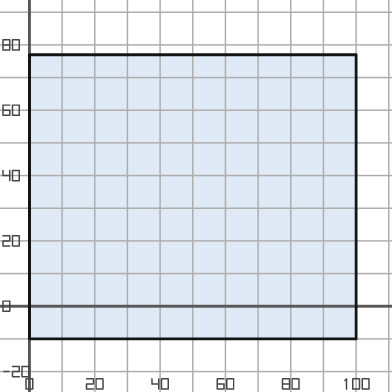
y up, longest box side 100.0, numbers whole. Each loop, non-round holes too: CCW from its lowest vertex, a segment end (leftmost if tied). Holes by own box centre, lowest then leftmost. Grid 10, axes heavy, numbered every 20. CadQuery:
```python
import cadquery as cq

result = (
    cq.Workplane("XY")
    .moveTo(0.0, -10.0)
    .lineTo(100.0, -10.0)
    .lineTo(100.0, 77.0)
    .lineTo(0.0, 77.0)
    .close()
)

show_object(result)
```